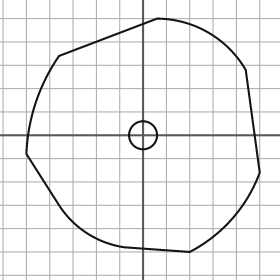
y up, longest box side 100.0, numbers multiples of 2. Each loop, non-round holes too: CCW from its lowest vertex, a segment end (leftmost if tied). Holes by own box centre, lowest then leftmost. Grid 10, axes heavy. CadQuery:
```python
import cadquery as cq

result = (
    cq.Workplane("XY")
    .moveTo(20.0, -50.0)
    .threePointArc((38.0, -36.0), (50.0, -16.0))
    .lineTo(44.0, 28.0)
    .threePointArc((28.0, 44.0), (6.0, 50.0))
    .lineTo(-36.0, 34.0)
    .threePointArc((-46.0, 14.0), (-50.0, -8.0))
    .lineTo(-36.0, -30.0)
    .threePointArc((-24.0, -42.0), (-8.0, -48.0))
    .close()
    .moveTo(0.0, 0.0)
    .circle(6.0)
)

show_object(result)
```